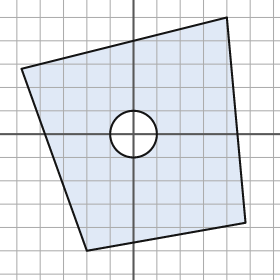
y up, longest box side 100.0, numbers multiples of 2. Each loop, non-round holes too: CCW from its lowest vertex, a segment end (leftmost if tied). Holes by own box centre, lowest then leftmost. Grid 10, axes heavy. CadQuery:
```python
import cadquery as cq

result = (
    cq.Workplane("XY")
    .moveTo(-20.0, -50.0)
    .lineTo(48.0, -38.0)
    .lineTo(40.0, 50.0)
    .lineTo(-48.0, 28.0)
    .close()
    .moveTo(0.0, 0.0)
    .circle(10.0)
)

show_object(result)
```